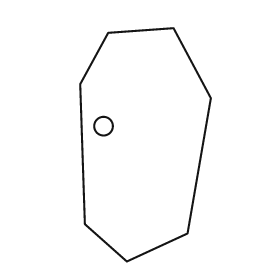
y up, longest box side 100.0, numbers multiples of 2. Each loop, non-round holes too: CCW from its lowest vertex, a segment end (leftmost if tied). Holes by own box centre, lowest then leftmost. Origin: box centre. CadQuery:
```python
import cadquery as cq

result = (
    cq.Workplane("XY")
    .moveTo(-8.0, -50.0)
    .lineTo(18.0, -38.0)
    .lineTo(28.0, 20.0)
    .lineTo(12.0, 50.0)
    .lineTo(-16.0, 48.0)
    .lineTo(-28.0, 26.0)
    .lineTo(-26.0, -34.0)
    .close()
    .moveTo(-18.0, 8.0)
    .circle(4.0)
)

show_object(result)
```